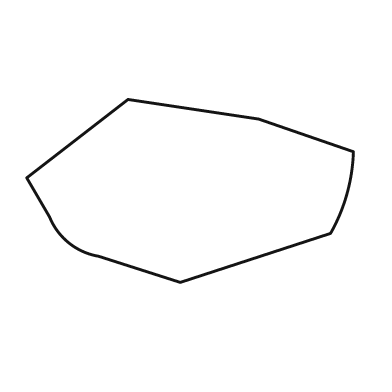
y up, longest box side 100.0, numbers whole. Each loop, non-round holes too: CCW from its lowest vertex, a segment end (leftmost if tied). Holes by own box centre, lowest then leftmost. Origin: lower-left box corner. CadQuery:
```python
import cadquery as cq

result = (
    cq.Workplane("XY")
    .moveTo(47.0, 0.0)
    .lineTo(93.0, 15.0)
    .threePointArc((98.0, 27.0), (100.0, 40.0))
    .lineTo(71.0, 50.0)
    .lineTo(31.0, 56.0)
    .lineTo(0.0, 32.0)
    .lineTo(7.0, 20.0)
    .threePointArc((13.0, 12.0), (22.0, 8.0))
    .close()
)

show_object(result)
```